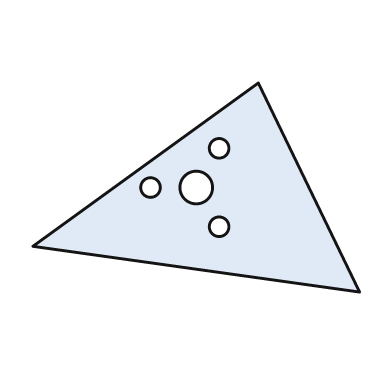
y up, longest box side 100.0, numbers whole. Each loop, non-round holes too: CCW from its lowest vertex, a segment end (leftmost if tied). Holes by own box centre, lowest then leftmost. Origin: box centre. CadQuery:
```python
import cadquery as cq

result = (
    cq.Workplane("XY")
    .moveTo(50.0, -32.0)
    .lineTo(19.0, 32.0)
    .lineTo(-50.0, -18.0)
    .close()
    .moveTo(7.0, -12.0)
    .circle(3.0)
    .moveTo(-14.0, 0.0)
    .circle(3.0)
    .moveTo(0.0, 0.0)
    .circle(5.0)
    .moveTo(7.0, 12.0)
    .circle(3.0)
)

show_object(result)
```